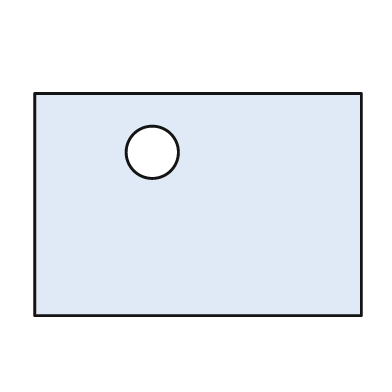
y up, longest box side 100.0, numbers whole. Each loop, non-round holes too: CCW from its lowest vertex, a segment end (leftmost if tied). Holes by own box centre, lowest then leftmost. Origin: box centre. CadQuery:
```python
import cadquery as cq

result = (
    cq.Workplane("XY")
    .moveTo(-50.0, -34.0)
    .lineTo(50.0, -34.0)
    .lineTo(50.0, 34.0)
    .lineTo(-50.0, 34.0)
    .close()
    .moveTo(-14.0, 16.0)
    .circle(8.0)
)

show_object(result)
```